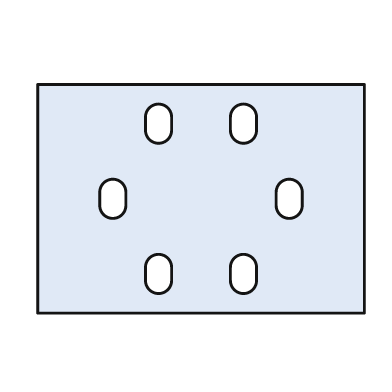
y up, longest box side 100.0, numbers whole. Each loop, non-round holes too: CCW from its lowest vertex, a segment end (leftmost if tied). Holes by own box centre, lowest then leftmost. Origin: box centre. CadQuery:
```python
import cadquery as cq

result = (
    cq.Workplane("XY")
    .moveTo(-50.0, -35.0)
    .lineTo(50.0, -35.0)
    .lineTo(50.0, 35.0)
    .lineTo(-50.0, 35.0)
    .close()
    .moveTo(-17.0, -25.0)
    .threePointArc((-13.0, -29.0), (-9.0, -25.0))
    .lineTo(-9.0, -21.0)
    .threePointArc((-13.0, -17.0), (-17.0, -21.0))
    .close()
    .moveTo(9.0, -25.0)
    .threePointArc((13.0, -29.0), (17.0, -25.0))
    .lineTo(17.0, -21.0)
    .threePointArc((13.0, -17.0), (9.0, -21.0))
    .close()
    .moveTo(-31.0, -2.0)
    .threePointArc((-27.0, -6.0), (-23.0, -2.0))
    .lineTo(-23.0, 2.0)
    .threePointArc((-27.0, 6.0), (-31.0, 2.0))
    .close()
    .moveTo(23.0, -2.0)
    .threePointArc((27.0, -6.0), (31.0, -2.0))
    .lineTo(31.0, 2.0)
    .threePointArc((27.0, 6.0), (23.0, 2.0))
    .close()
    .moveTo(-17.0, 21.0)
    .threePointArc((-13.0, 17.0), (-9.0, 21.0))
    .lineTo(-9.0, 25.0)
    .threePointArc((-13.0, 29.0), (-17.0, 25.0))
    .close()
    .moveTo(9.0, 21.0)
    .threePointArc((13.0, 17.0), (17.0, 21.0))
    .lineTo(17.0, 25.0)
    .threePointArc((13.0, 29.0), (9.0, 25.0))
    .close()
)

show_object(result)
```